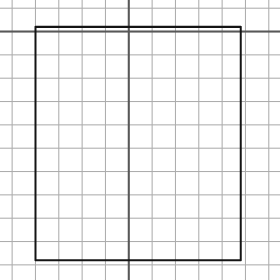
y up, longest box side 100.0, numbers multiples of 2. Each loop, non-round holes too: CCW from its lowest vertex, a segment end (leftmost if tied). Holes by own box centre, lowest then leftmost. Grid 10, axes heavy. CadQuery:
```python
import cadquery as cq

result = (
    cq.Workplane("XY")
    .moveTo(-40.0, -98.0)
    .lineTo(48.0, -98.0)
    .lineTo(48.0, 2.0)
    .lineTo(-40.0, 2.0)
    .close()
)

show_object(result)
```